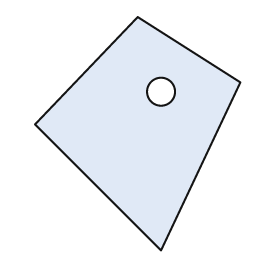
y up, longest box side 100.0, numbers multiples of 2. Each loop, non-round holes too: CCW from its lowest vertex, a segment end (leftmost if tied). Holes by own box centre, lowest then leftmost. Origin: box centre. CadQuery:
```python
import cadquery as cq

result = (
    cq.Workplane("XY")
    .moveTo(10.0, -50.0)
    .lineTo(44.0, 22.0)
    .lineTo(0.0, 50.0)
    .lineTo(-44.0, 4.0)
    .close()
    .moveTo(10.0, 18.0)
    .circle(6.0)
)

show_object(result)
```